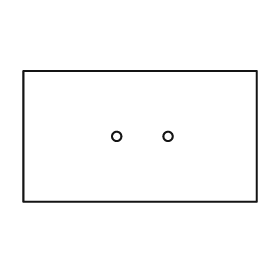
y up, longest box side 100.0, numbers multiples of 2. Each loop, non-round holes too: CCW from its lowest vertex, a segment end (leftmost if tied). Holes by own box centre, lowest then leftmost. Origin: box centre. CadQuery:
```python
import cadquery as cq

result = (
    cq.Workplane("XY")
    .moveTo(-50.0, -28.0)
    .lineTo(50.0, -28.0)
    .lineTo(50.0, 28.0)
    .lineTo(-50.0, 28.0)
    .close()
    .moveTo(-10.0, 0.0)
    .circle(2.0)
    .moveTo(12.0, 0.0)
    .circle(2.0)
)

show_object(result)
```